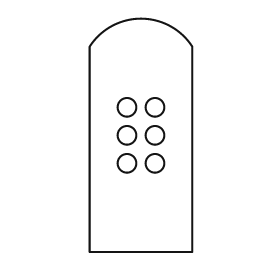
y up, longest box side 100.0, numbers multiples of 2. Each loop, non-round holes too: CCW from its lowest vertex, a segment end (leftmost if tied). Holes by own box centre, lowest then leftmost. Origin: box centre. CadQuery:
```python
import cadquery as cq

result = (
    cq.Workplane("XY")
    .moveTo(-22.0, -50.0)
    .lineTo(22.0, -50.0)
    .lineTo(22.0, 38.0)
    .threePointArc((0.0, 50.0), (-22.0, 38.0))
    .close()
    .moveTo(-6.0, -12.0)
    .circle(4.0)
    .moveTo(6.0, -12.0)
    .circle(4.0)
    .moveTo(-6.0, 0.0)
    .circle(4.0)
    .moveTo(6.0, 0.0)
    .circle(4.0)
    .moveTo(-6.0, 12.0)
    .circle(4.0)
    .moveTo(6.0, 12.0)
    .circle(4.0)
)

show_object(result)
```